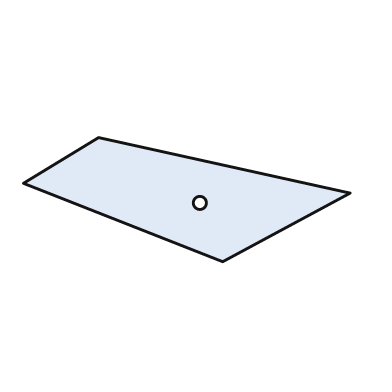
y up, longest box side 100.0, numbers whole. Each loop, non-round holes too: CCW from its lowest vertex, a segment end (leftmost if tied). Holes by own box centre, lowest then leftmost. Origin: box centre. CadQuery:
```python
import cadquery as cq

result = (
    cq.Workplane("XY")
    .moveTo(11.0, -19.0)
    .lineTo(50.0, 2.0)
    .lineTo(-27.0, 19.0)
    .lineTo(-50.0, 5.0)
    .close()
    .moveTo(4.0, -1.0)
    .circle(2.0)
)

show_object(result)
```